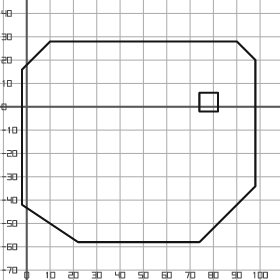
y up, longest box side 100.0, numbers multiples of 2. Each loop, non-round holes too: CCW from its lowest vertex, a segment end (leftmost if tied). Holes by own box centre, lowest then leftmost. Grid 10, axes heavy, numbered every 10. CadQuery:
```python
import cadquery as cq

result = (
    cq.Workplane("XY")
    .moveTo(22.0, -58.0)
    .lineTo(74.0, -58.0)
    .lineTo(98.0, -34.0)
    .lineTo(98.0, 20.0)
    .lineTo(90.0, 28.0)
    .lineTo(10.0, 28.0)
    .lineTo(-2.0, 16.0)
    .lineTo(-2.0, -42.0)
    .close()
    .moveTo(74.0, -2.0)
    .lineTo(82.0, -2.0)
    .lineTo(82.0, 6.0)
    .lineTo(74.0, 6.0)
    .close()
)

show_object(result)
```